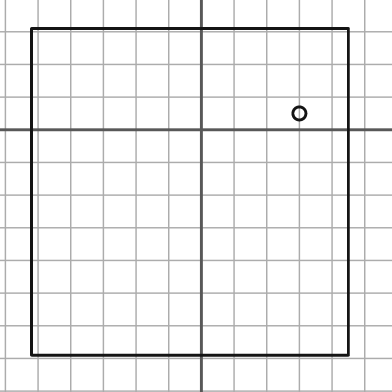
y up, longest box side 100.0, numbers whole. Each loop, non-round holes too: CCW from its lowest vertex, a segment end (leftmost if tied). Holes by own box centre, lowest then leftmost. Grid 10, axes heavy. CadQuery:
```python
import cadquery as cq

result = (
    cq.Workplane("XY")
    .moveTo(-52.0, -69.0)
    .lineTo(45.0, -69.0)
    .lineTo(45.0, 31.0)
    .lineTo(-52.0, 31.0)
    .close()
    .moveTo(30.0, 5.0)
    .circle(2.0)
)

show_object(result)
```